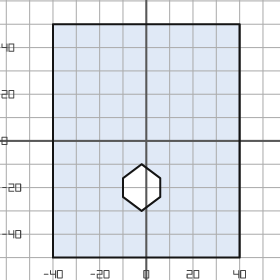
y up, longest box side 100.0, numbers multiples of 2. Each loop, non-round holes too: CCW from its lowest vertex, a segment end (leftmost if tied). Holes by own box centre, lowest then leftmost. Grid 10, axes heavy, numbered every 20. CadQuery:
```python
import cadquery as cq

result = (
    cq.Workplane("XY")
    .moveTo(-40.0, -50.0)
    .lineTo(40.0, -50.0)
    .lineTo(40.0, 50.0)
    .lineTo(-40.0, 50.0)
    .close()
    .moveTo(-2.0, -30.0)
    .lineTo(6.0, -24.0)
    .lineTo(6.0, -16.0)
    .lineTo(-2.0, -10.0)
    .lineTo(-10.0, -16.0)
    .lineTo(-10.0, -24.0)
    .close()
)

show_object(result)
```